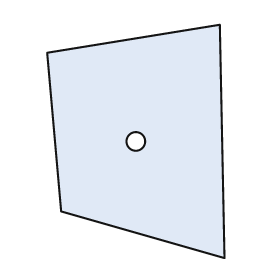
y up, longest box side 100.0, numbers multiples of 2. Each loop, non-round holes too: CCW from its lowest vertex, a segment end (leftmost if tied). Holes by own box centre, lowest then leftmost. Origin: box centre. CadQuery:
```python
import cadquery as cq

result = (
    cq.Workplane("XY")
    .moveTo(38.0, -50.0)
    .lineTo(36.0, 50.0)
    .lineTo(-38.0, 38.0)
    .lineTo(-32.0, -30.0)
    .close()
    .moveTo(0.0, 0.0)
    .circle(4.0)
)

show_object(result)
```